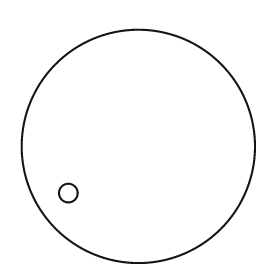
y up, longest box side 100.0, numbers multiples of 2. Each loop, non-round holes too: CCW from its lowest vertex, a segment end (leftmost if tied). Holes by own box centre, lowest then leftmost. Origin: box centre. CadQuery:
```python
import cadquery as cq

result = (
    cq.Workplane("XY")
    .moveTo(0.0, 0.0)
    .circle(50.0)
    .moveTo(-30.0, -20.0)
    .circle(4.0)
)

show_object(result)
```